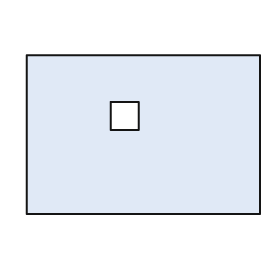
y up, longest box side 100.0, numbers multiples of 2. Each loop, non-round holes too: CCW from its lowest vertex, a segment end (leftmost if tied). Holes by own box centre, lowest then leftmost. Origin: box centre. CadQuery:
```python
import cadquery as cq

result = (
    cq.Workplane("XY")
    .moveTo(-50.0, -34.0)
    .lineTo(50.0, -34.0)
    .lineTo(50.0, 34.0)
    .lineTo(-50.0, 34.0)
    .close()
    .moveTo(-14.0, 2.0)
    .lineTo(-2.0, 2.0)
    .lineTo(-2.0, 14.0)
    .lineTo(-14.0, 14.0)
    .close()
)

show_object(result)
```